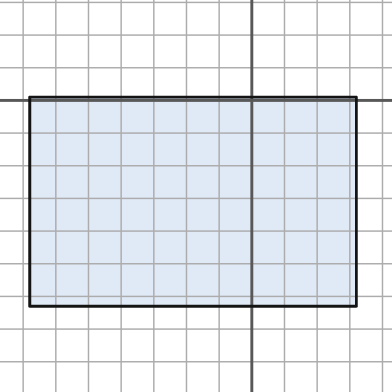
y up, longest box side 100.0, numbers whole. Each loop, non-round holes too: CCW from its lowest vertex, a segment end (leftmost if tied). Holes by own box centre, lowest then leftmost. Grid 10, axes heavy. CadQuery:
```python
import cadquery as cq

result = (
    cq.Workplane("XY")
    .moveTo(-68.0, -63.0)
    .lineTo(32.0, -63.0)
    .lineTo(32.0, 1.0)
    .lineTo(-68.0, 1.0)
    .close()
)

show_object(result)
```